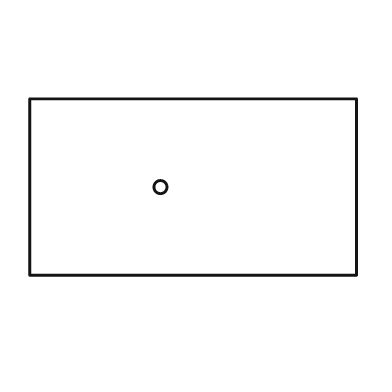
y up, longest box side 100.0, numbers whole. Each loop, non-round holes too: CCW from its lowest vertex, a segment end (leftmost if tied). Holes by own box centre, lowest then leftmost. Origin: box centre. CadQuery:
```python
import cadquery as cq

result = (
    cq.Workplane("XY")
    .moveTo(-50.0, -27.0)
    .lineTo(50.0, -27.0)
    .lineTo(50.0, 27.0)
    .lineTo(-50.0, 27.0)
    .close()
    .moveTo(-10.0, 0.0)
    .circle(2.0)
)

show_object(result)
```